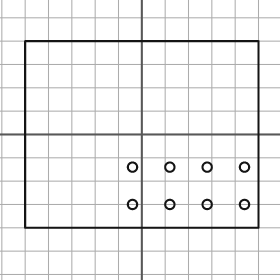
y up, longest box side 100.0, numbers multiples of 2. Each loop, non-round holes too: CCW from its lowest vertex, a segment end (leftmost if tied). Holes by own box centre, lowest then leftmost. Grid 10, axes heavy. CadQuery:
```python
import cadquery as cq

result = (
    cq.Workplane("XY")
    .moveTo(-50.0, -40.0)
    .lineTo(50.0, -40.0)
    .lineTo(50.0, 40.0)
    .lineTo(-50.0, 40.0)
    .close()
    .moveTo(-4.0, -30.0)
    .circle(2.0)
    .moveTo(12.0, -30.0)
    .circle(2.0)
    .moveTo(28.0, -30.0)
    .circle(2.0)
    .moveTo(44.0, -30.0)
    .circle(2.0)
    .moveTo(-4.0, -14.0)
    .circle(2.0)
    .moveTo(12.0, -14.0)
    .circle(2.0)
    .moveTo(28.0, -14.0)
    .circle(2.0)
    .moveTo(44.0, -14.0)
    .circle(2.0)
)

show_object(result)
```